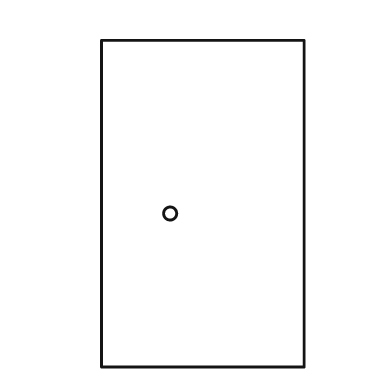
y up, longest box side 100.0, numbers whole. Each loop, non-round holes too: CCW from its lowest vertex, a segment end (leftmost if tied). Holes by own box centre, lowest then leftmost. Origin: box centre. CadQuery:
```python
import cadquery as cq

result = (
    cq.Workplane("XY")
    .moveTo(-31.0, -50.0)
    .lineTo(31.0, -50.0)
    .lineTo(31.0, 50.0)
    .lineTo(-31.0, 50.0)
    .close()
    .moveTo(-10.0, -3.0)
    .circle(2.0)
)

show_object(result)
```